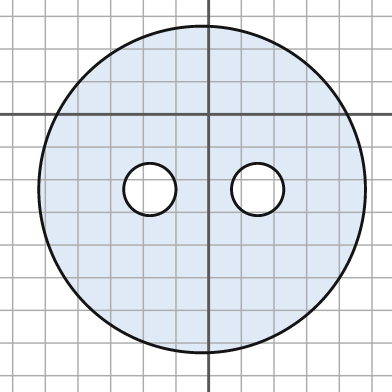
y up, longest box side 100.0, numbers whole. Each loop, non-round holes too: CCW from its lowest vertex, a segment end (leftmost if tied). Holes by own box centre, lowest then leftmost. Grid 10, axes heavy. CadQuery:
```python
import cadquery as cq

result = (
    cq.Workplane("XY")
    .moveTo(-2.0, -23.0)
    .circle(50.0)
    .moveTo(-18.0, -23.0)
    .circle(8.0)
    .moveTo(15.0, -23.0)
    .circle(8.0)
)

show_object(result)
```